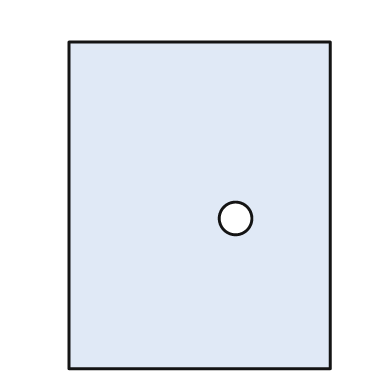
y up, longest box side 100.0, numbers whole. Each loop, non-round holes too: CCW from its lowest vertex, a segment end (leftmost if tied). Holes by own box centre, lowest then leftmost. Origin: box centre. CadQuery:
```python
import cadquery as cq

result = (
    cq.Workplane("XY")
    .moveTo(-40.0, -50.0)
    .lineTo(40.0, -50.0)
    .lineTo(40.0, 50.0)
    .lineTo(-40.0, 50.0)
    .close()
    .moveTo(11.0, -4.0)
    .circle(5.0)
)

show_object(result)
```